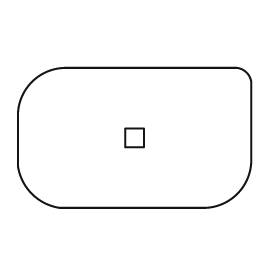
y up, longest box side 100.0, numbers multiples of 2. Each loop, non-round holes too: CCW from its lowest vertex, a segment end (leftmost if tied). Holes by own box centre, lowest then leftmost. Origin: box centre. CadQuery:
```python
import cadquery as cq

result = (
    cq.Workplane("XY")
    .moveTo(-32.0, -30.0)
    .lineTo(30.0, -30.0)
    .threePointArc((44.0, -24.0), (50.0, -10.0))
    .lineTo(50.0, 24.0)
    .threePointArc((48.0, 28.0), (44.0, 30.0))
    .lineTo(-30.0, 30.0)
    .threePointArc((-44.0, 24.0), (-50.0, 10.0))
    .lineTo(-50.0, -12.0)
    .threePointArc((-44.0, -24.0), (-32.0, -30.0))
    .close()
    .moveTo(-4.0, -4.0)
    .lineTo(4.0, -4.0)
    .lineTo(4.0, 4.0)
    .lineTo(-4.0, 4.0)
    .close()
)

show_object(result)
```